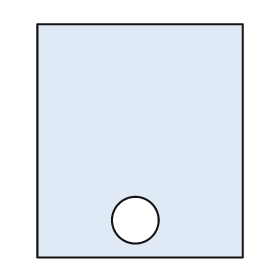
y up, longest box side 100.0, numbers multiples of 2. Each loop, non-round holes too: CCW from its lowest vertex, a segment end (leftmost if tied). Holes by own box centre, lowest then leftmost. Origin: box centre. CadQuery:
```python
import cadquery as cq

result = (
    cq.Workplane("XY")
    .moveTo(-44.0, -50.0)
    .lineTo(44.0, -50.0)
    .lineTo(44.0, 50.0)
    .lineTo(-44.0, 50.0)
    .close()
    .moveTo(-2.0, -34.0)
    .circle(10.0)
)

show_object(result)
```